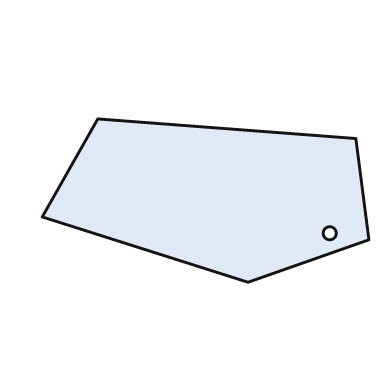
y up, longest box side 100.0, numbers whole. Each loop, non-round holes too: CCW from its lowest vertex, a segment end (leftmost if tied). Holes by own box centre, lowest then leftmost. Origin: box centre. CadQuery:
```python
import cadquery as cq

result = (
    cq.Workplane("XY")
    .moveTo(13.0, -25.0)
    .lineTo(50.0, -12.0)
    .lineTo(46.0, 19.0)
    .lineTo(-33.0, 25.0)
    .lineTo(-50.0, -5.0)
    .close()
    .moveTo(38.0, -10.0)
    .circle(2.0)
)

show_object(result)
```